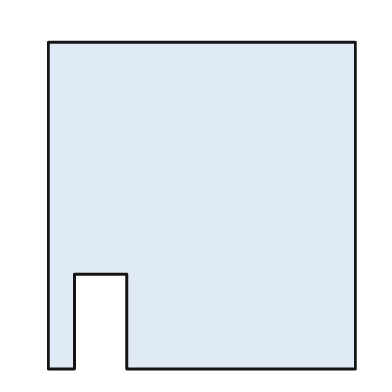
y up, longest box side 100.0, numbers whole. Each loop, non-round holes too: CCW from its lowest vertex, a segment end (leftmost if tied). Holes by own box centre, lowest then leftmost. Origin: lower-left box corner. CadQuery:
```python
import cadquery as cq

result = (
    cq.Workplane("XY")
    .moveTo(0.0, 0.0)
    .lineTo(8.0, 0.0)
    .lineTo(8.0, 29.0)
    .lineTo(24.0, 29.0)
    .lineTo(24.0, 0.0)
    .lineTo(94.0, 0.0)
    .lineTo(94.0, 100.0)
    .lineTo(0.0, 100.0)
    .close()
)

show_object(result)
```